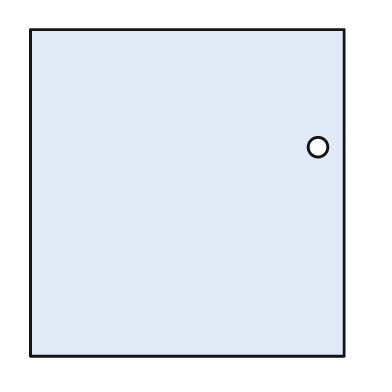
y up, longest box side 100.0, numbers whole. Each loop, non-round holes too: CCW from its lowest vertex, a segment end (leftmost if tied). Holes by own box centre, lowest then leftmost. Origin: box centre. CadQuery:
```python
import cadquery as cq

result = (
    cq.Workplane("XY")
    .moveTo(-48.0, -50.0)
    .lineTo(48.0, -50.0)
    .lineTo(48.0, 50.0)
    .lineTo(-48.0, 50.0)
    .close()
    .moveTo(40.0, 14.0)
    .circle(3.0)
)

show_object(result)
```